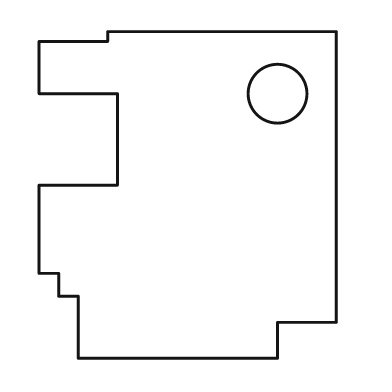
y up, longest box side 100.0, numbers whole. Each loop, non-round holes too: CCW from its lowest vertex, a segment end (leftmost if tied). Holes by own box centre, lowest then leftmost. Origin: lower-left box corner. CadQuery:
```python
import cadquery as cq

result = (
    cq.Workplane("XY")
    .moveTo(12.0, 0.0)
    .lineTo(73.0, 0.0)
    .lineTo(73.0, 11.0)
    .lineTo(91.0, 11.0)
    .lineTo(91.0, 100.0)
    .lineTo(21.0, 100.0)
    .lineTo(21.0, 97.0)
    .lineTo(0.0, 97.0)
    .lineTo(0.0, 81.0)
    .lineTo(24.0, 81.0)
    .lineTo(24.0, 53.0)
    .lineTo(0.0, 53.0)
    .lineTo(0.0, 26.0)
    .lineTo(6.0, 26.0)
    .lineTo(6.0, 19.0)
    .lineTo(12.0, 19.0)
    .close()
    .moveTo(73.0, 81.0)
    .circle(9.0)
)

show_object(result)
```